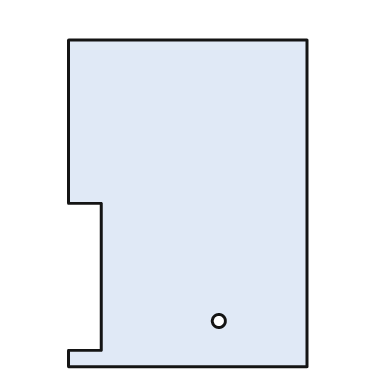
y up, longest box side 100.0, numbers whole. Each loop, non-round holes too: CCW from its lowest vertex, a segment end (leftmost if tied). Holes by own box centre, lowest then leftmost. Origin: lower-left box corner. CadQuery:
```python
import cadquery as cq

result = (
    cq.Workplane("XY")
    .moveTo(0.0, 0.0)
    .lineTo(73.0, 0.0)
    .lineTo(73.0, 100.0)
    .lineTo(0.0, 100.0)
    .lineTo(0.0, 50.0)
    .lineTo(10.0, 50.0)
    .lineTo(10.0, 5.0)
    .lineTo(0.0, 5.0)
    .close()
    .moveTo(46.0, 14.0)
    .circle(2.0)
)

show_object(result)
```